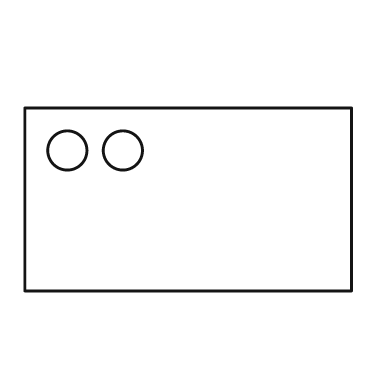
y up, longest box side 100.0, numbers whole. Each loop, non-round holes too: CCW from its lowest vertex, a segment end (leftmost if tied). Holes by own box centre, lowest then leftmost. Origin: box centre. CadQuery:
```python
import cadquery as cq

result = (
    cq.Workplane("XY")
    .moveTo(-50.0, -28.0)
    .lineTo(50.0, -28.0)
    .lineTo(50.0, 28.0)
    .lineTo(-50.0, 28.0)
    .close()
    .moveTo(-37.0, 15.0)
    .circle(6.0)
    .moveTo(-20.0, 15.0)
    .circle(6.0)
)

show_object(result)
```